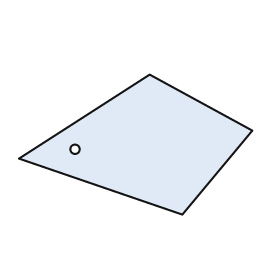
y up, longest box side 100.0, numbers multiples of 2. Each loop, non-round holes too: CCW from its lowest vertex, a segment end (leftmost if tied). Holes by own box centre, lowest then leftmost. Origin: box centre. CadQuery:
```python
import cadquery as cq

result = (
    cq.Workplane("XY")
    .moveTo(20.0, -30.0)
    .lineTo(50.0, 6.0)
    .lineTo(6.0, 30.0)
    .lineTo(-50.0, -6.0)
    .close()
    .moveTo(-26.0, -2.0)
    .circle(2.0)
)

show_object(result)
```